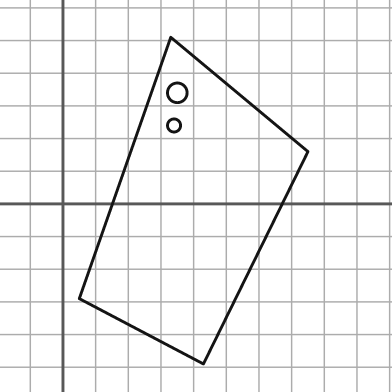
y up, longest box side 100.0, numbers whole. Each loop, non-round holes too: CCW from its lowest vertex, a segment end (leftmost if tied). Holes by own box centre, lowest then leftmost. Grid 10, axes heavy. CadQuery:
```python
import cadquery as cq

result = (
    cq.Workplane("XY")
    .moveTo(43.0, -49.0)
    .lineTo(75.0, 16.0)
    .lineTo(33.0, 51.0)
    .lineTo(5.0, -29.0)
    .close()
    .moveTo(34.0, 24.0)
    .circle(2.0)
    .moveTo(35.0, 34.0)
    .circle(3.0)
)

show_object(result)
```